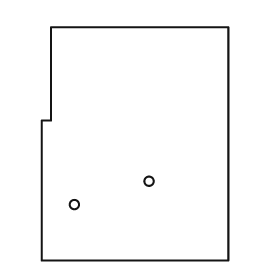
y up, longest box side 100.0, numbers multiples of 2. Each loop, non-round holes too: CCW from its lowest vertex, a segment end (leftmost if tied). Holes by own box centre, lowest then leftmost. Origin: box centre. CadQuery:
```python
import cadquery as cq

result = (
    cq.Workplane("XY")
    .moveTo(-40.0, -50.0)
    .lineTo(40.0, -50.0)
    .lineTo(40.0, 50.0)
    .lineTo(-36.0, 50.0)
    .lineTo(-36.0, 10.0)
    .lineTo(-40.0, 10.0)
    .close()
    .moveTo(-26.0, -26.0)
    .circle(2.0)
    .moveTo(6.0, -16.0)
    .circle(2.0)
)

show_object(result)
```